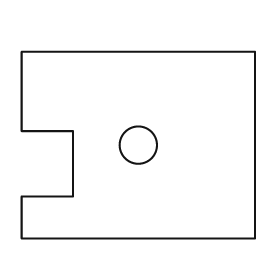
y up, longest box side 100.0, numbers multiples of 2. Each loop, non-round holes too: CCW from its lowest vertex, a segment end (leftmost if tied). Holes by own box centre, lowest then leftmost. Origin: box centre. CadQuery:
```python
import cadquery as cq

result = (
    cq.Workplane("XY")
    .moveTo(-50.0, -40.0)
    .lineTo(50.0, -40.0)
    .lineTo(50.0, 40.0)
    .lineTo(-50.0, 40.0)
    .lineTo(-50.0, 6.0)
    .lineTo(-28.0, 6.0)
    .lineTo(-28.0, -22.0)
    .lineTo(-50.0, -22.0)
    .close()
    .moveTo(0.0, 0.0)
    .circle(8.0)
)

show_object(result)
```